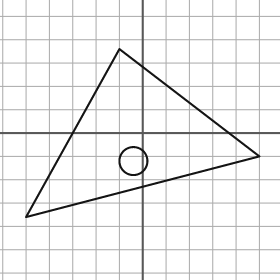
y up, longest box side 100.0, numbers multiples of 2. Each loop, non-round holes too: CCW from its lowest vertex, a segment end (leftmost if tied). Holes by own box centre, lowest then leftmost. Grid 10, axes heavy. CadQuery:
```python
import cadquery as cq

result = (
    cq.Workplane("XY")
    .moveTo(-50.0, -36.0)
    .lineTo(50.0, -10.0)
    .lineTo(-10.0, 36.0)
    .close()
    .moveTo(-4.0, -12.0)
    .circle(6.0)
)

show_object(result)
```